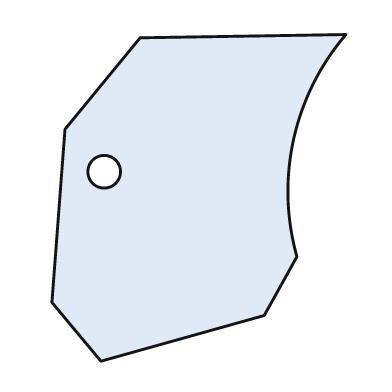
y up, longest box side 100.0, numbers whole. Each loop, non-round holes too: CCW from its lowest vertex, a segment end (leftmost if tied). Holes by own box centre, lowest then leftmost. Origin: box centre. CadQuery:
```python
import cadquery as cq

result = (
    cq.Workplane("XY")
    .moveTo(-30.0, -50.0)
    .lineTo(20.0, -36.0)
    .lineTo(30.0, -18.0)
    .threePointArc((29.0, 18.0), (45.0, 50.0))
    .lineTo(-18.0, 49.0)
    .lineTo(-41.0, 21.0)
    .lineTo(-45.0, -32.0)
    .close()
    .moveTo(-29.0, 8.0)
    .circle(5.0)
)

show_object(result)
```